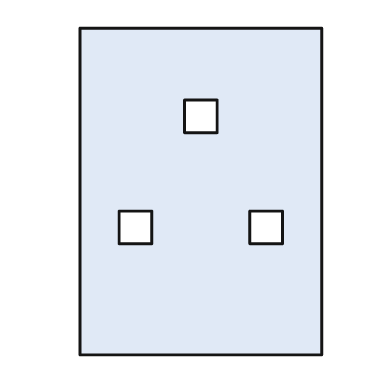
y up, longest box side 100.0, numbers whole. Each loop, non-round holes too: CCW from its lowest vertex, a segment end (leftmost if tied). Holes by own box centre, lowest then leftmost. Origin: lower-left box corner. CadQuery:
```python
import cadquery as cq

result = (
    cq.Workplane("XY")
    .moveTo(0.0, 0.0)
    .lineTo(74.0, 0.0)
    .lineTo(74.0, 100.0)
    .lineTo(0.0, 100.0)
    .close()
    .moveTo(12.0, 34.0)
    .lineTo(22.0, 34.0)
    .lineTo(22.0, 44.0)
    .lineTo(12.0, 44.0)
    .close()
    .moveTo(52.0, 34.0)
    .lineTo(62.0, 34.0)
    .lineTo(62.0, 44.0)
    .lineTo(52.0, 44.0)
    .close()
    .moveTo(32.0, 68.0)
    .lineTo(42.0, 68.0)
    .lineTo(42.0, 78.0)
    .lineTo(32.0, 78.0)
    .close()
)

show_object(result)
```